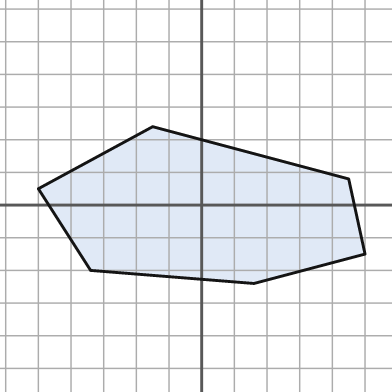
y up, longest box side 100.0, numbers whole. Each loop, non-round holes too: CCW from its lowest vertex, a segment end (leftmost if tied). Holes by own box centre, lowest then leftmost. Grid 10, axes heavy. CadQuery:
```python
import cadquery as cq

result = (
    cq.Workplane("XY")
    .moveTo(16.0, -24.0)
    .lineTo(50.0, -15.0)
    .lineTo(45.0, 8.0)
    .lineTo(-15.0, 24.0)
    .lineTo(-50.0, 5.0)
    .lineTo(-34.0, -20.0)
    .close()
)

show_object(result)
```